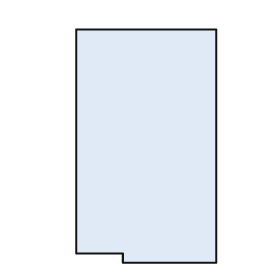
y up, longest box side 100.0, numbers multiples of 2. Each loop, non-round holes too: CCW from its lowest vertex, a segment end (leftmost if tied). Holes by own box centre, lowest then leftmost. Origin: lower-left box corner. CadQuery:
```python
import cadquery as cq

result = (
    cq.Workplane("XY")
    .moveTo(20.0, 0.0)
    .lineTo(60.0, 0.0)
    .lineTo(60.0, 100.0)
    .lineTo(0.0, 100.0)
    .lineTo(0.0, 4.0)
    .lineTo(20.0, 4.0)
    .close()
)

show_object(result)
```